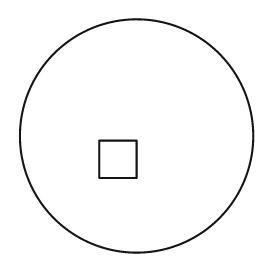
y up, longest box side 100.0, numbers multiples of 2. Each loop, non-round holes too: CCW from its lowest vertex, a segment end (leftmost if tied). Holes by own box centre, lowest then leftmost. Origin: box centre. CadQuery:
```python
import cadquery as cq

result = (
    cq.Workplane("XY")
    .moveTo(0.0, 0.0)
    .circle(50.0)
    .moveTo(-16.0, -18.0)
    .lineTo(0.0, -18.0)
    .lineTo(0.0, -2.0)
    .lineTo(-16.0, -2.0)
    .close()
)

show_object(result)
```